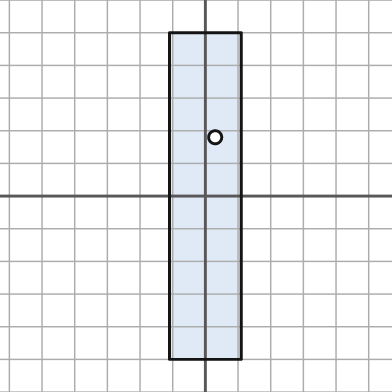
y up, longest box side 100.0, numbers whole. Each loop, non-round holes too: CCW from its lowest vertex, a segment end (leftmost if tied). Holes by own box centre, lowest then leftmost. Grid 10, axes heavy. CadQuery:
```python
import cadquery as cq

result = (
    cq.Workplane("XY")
    .moveTo(-11.0, -50.0)
    .lineTo(11.0, -50.0)
    .lineTo(11.0, 50.0)
    .lineTo(-11.0, 50.0)
    .close()
    .moveTo(3.0, 18.0)
    .circle(2.0)
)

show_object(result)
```